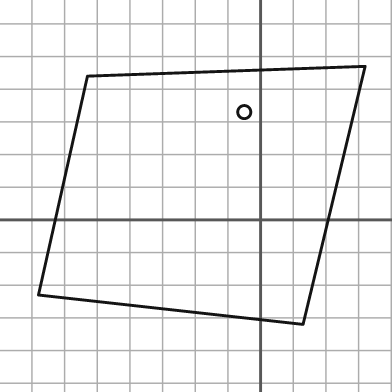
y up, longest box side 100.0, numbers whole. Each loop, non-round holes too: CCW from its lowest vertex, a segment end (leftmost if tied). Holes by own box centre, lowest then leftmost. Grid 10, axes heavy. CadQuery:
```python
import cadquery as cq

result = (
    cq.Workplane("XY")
    .moveTo(13.0, -32.0)
    .lineTo(32.0, 47.0)
    .lineTo(-53.0, 44.0)
    .lineTo(-68.0, -23.0)
    .close()
    .moveTo(-5.0, 33.0)
    .circle(2.0)
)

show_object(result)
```